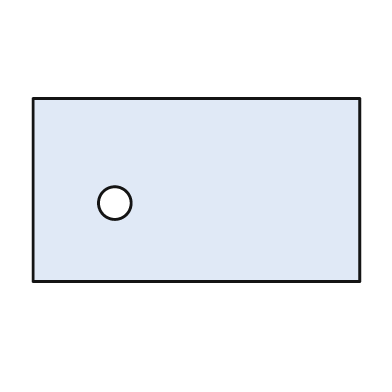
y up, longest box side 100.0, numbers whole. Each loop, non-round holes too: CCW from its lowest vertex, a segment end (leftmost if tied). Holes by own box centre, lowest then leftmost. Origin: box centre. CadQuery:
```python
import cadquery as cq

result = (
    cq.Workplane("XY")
    .moveTo(-50.0, -28.0)
    .lineTo(50.0, -28.0)
    .lineTo(50.0, 28.0)
    .lineTo(-50.0, 28.0)
    .close()
    .moveTo(-25.0, -4.0)
    .circle(5.0)
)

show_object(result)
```